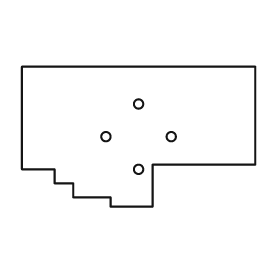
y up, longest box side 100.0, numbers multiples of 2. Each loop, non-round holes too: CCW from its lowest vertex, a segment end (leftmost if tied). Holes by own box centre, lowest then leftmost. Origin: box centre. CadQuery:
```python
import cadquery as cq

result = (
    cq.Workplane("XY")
    .moveTo(-12.0, -30.0)
    .lineTo(6.0, -30.0)
    .lineTo(6.0, -12.0)
    .lineTo(50.0, -12.0)
    .lineTo(50.0, 30.0)
    .lineTo(-50.0, 30.0)
    .lineTo(-50.0, -14.0)
    .lineTo(-36.0, -14.0)
    .lineTo(-36.0, -20.0)
    .lineTo(-28.0, -20.0)
    .lineTo(-28.0, -26.0)
    .lineTo(-12.0, -26.0)
    .close()
    .moveTo(0.0, -14.0)
    .circle(2.0)
    .moveTo(-14.0, 0.0)
    .circle(2.0)
    .moveTo(14.0, 0.0)
    .circle(2.0)
    .moveTo(0.0, 14.0)
    .circle(2.0)
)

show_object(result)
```